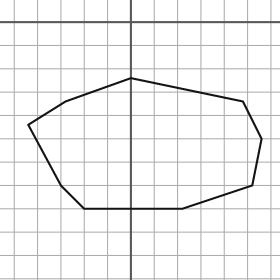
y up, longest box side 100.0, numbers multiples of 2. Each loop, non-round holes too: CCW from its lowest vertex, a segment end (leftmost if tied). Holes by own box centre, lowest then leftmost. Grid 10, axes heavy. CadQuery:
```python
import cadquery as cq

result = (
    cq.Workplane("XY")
    .moveTo(-20.0, -80.0)
    .lineTo(22.0, -80.0)
    .lineTo(52.0, -70.0)
    .lineTo(56.0, -50.0)
    .lineTo(48.0, -34.0)
    .lineTo(0.0, -24.0)
    .lineTo(-28.0, -34.0)
    .lineTo(-44.0, -44.0)
    .lineTo(-30.0, -70.0)
    .close()
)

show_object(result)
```